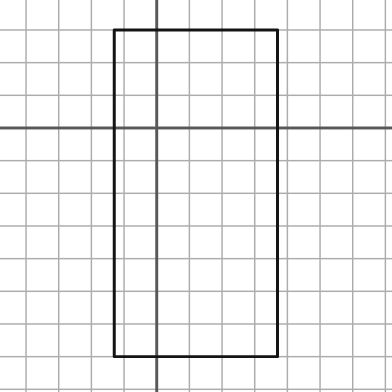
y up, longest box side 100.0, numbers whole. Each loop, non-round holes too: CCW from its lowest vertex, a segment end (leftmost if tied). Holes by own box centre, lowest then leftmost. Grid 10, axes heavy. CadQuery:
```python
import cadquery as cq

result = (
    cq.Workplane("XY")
    .moveTo(-13.0, -70.0)
    .lineTo(37.0, -70.0)
    .lineTo(37.0, 30.0)
    .lineTo(-13.0, 30.0)
    .close()
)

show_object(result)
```